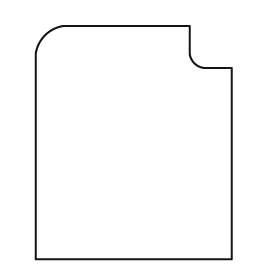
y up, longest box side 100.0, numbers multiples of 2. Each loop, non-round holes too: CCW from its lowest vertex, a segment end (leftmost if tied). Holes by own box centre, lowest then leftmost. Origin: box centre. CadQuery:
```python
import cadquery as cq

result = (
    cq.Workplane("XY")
    .moveTo(-42.0, -50.0)
    .lineTo(42.0, -50.0)
    .lineTo(42.0, 32.0)
    .lineTo(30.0, 32.0)
    .threePointArc((26.0, 34.0), (24.0, 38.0))
    .lineTo(24.0, 50.0)
    .lineTo(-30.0, 50.0)
    .threePointArc((-38.0, 46.0), (-42.0, 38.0))
    .close()
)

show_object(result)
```